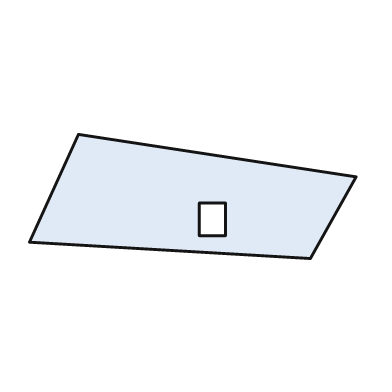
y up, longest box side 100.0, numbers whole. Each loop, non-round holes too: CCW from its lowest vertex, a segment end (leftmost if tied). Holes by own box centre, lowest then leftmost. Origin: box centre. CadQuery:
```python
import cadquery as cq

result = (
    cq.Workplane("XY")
    .moveTo(36.0, -19.0)
    .lineTo(50.0, 6.0)
    .lineTo(-35.0, 19.0)
    .lineTo(-50.0, -14.0)
    .close()
    .moveTo(2.0, -12.0)
    .lineTo(10.0, -12.0)
    .lineTo(10.0, -2.0)
    .lineTo(2.0, -2.0)
    .close()
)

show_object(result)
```